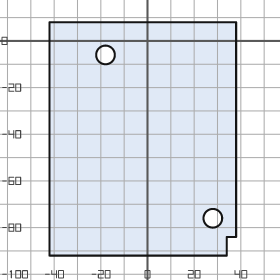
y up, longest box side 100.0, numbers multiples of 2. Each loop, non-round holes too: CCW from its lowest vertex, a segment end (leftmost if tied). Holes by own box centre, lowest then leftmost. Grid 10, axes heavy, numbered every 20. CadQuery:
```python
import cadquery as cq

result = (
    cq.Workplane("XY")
    .moveTo(-42.0, -92.0)
    .lineTo(34.0, -92.0)
    .lineTo(34.0, -84.0)
    .lineTo(38.0, -84.0)
    .lineTo(38.0, 8.0)
    .lineTo(-42.0, 8.0)
    .close()
    .moveTo(28.0, -76.0)
    .circle(4.0)
    .moveTo(-18.0, -6.0)
    .circle(4.0)
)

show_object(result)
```